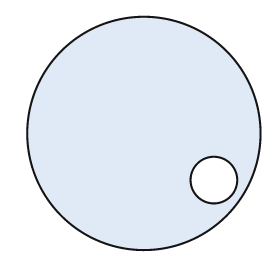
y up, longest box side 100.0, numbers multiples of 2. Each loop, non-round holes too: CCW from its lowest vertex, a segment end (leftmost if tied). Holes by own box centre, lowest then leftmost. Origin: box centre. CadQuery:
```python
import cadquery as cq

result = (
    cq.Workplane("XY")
    .moveTo(0.0, 0.0)
    .circle(50.0)
    .moveTo(30.0, -20.0)
    .circle(10.0)
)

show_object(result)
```